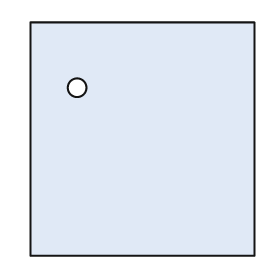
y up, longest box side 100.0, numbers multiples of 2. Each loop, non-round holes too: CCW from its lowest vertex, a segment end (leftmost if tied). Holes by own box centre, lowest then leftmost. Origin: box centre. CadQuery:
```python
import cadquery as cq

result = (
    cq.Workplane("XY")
    .moveTo(-48.0, -50.0)
    .lineTo(48.0, -50.0)
    .lineTo(48.0, 50.0)
    .lineTo(-48.0, 50.0)
    .close()
    .moveTo(-28.0, 22.0)
    .circle(4.0)
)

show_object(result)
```